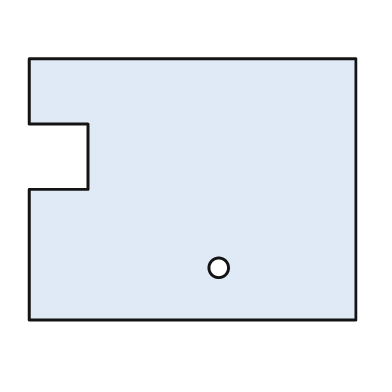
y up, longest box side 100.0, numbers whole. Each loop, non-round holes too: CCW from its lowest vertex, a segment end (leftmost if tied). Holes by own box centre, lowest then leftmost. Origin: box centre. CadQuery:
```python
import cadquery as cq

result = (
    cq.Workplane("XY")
    .moveTo(-50.0, -40.0)
    .lineTo(50.0, -40.0)
    .lineTo(50.0, 40.0)
    .lineTo(-50.0, 40.0)
    .lineTo(-50.0, 20.0)
    .lineTo(-32.0, 20.0)
    .lineTo(-32.0, 0.0)
    .lineTo(-50.0, 0.0)
    .close()
    .moveTo(8.0, -24.0)
    .circle(3.0)
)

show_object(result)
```